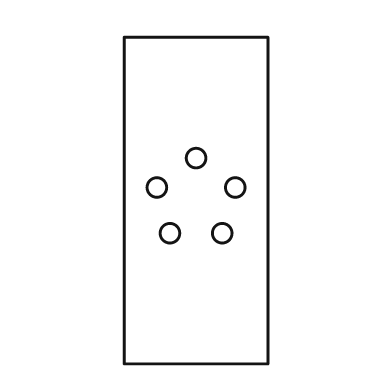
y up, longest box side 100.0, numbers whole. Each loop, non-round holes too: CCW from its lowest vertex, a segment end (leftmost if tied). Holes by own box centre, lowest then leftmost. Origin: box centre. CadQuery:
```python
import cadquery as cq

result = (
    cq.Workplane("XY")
    .moveTo(-22.0, -50.0)
    .lineTo(22.0, -50.0)
    .lineTo(22.0, 50.0)
    .lineTo(-22.0, 50.0)
    .close()
    .moveTo(-8.0, -10.0)
    .circle(3.0)
    .moveTo(8.0, -10.0)
    .circle(3.0)
    .moveTo(-12.0, 4.0)
    .circle(3.0)
    .moveTo(12.0, 4.0)
    .circle(3.0)
    .moveTo(0.0, 13.0)
    .circle(3.0)
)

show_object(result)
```